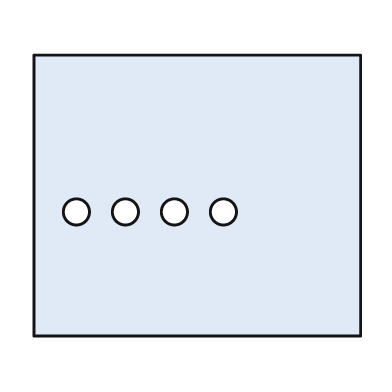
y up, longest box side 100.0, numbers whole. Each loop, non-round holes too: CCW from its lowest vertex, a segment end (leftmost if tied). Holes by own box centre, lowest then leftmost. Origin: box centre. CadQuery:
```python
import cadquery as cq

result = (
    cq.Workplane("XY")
    .moveTo(-50.0, -43.0)
    .lineTo(50.0, -43.0)
    .lineTo(50.0, 43.0)
    .lineTo(-50.0, 43.0)
    .close()
    .moveTo(-37.0, -5.0)
    .circle(4.0)
    .moveTo(-22.0, -5.0)
    .circle(4.0)
    .moveTo(-7.0, -5.0)
    .circle(4.0)
    .moveTo(8.0, -5.0)
    .circle(4.0)
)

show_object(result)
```